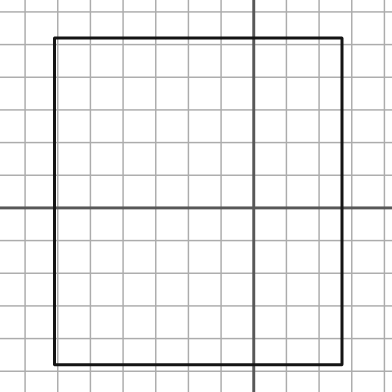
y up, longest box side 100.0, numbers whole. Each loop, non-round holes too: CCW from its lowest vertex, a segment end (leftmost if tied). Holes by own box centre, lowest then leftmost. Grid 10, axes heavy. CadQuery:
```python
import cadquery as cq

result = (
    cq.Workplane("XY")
    .moveTo(-61.0, -48.0)
    .lineTo(27.0, -48.0)
    .lineTo(27.0, 52.0)
    .lineTo(-61.0, 52.0)
    .close()
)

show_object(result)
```